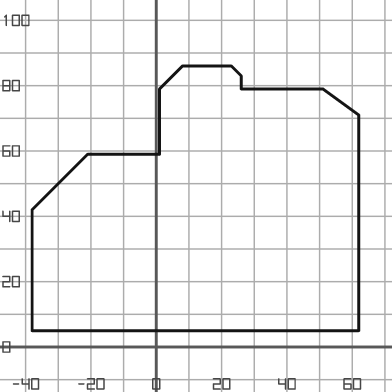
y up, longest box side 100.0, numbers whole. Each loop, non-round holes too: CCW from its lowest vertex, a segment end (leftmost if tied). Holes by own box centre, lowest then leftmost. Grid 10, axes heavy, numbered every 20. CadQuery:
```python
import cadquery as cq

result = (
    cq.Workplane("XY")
    .moveTo(-38.0, 5.0)
    .lineTo(62.0, 5.0)
    .lineTo(62.0, 71.0)
    .lineTo(51.0, 79.0)
    .lineTo(26.0, 79.0)
    .lineTo(26.0, 83.0)
    .lineTo(23.0, 86.0)
    .lineTo(8.0, 86.0)
    .lineTo(1.0, 79.0)
    .lineTo(1.0, 59.0)
    .lineTo(-21.0, 59.0)
    .lineTo(-38.0, 42.0)
    .close()
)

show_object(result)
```